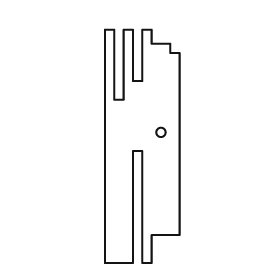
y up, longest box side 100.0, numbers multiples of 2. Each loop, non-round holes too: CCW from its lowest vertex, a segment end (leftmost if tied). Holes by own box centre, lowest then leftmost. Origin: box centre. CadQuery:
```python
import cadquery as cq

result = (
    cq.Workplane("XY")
    .moveTo(-16.0, -50.0)
    .lineTo(-4.0, -50.0)
    .lineTo(-4.0, -2.0)
    .lineTo(0.0, -2.0)
    .lineTo(0.0, -50.0)
    .lineTo(4.0, -50.0)
    .lineTo(4.0, -38.0)
    .lineTo(16.0, -38.0)
    .lineTo(16.0, 40.0)
    .lineTo(12.0, 40.0)
    .lineTo(12.0, 44.0)
    .lineTo(4.0, 44.0)
    .lineTo(4.0, 50.0)
    .lineTo(0.0, 50.0)
    .lineTo(0.0, 28.0)
    .lineTo(-4.0, 28.0)
    .lineTo(-4.0, 50.0)
    .lineTo(-8.0, 50.0)
    .lineTo(-8.0, 20.0)
    .lineTo(-12.0, 20.0)
    .lineTo(-12.0, 50.0)
    .lineTo(-16.0, 50.0)
    .close()
    .moveTo(8.0, 6.0)
    .circle(2.0)
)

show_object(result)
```